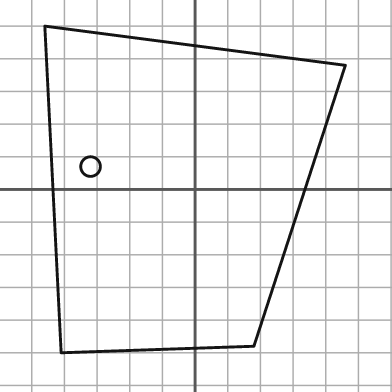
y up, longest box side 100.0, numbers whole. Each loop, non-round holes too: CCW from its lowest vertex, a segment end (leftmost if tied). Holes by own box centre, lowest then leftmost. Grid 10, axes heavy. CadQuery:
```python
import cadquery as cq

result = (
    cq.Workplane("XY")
    .moveTo(-41.0, -50.0)
    .lineTo(18.0, -48.0)
    .lineTo(46.0, 38.0)
    .lineTo(-46.0, 50.0)
    .close()
    .moveTo(-32.0, 7.0)
    .circle(3.0)
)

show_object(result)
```